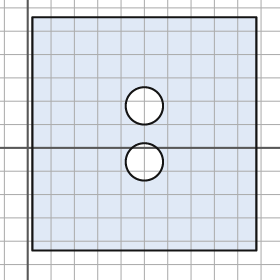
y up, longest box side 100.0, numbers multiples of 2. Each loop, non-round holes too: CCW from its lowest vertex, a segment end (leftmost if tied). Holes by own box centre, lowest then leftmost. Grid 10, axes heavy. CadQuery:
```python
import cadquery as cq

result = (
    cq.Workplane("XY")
    .moveTo(2.0, -44.0)
    .lineTo(98.0, -44.0)
    .lineTo(98.0, 56.0)
    .lineTo(2.0, 56.0)
    .close()
    .moveTo(50.0, -6.0)
    .circle(8.0)
    .moveTo(50.0, 18.0)
    .circle(8.0)
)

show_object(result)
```